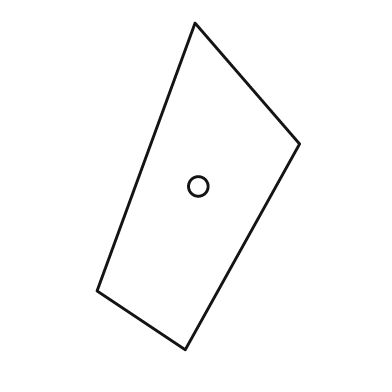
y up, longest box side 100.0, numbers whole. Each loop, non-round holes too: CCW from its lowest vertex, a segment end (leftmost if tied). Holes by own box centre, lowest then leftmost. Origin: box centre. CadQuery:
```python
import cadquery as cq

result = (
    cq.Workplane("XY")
    .moveTo(-4.0, -50.0)
    .lineTo(31.0, 13.0)
    .lineTo(-1.0, 50.0)
    .lineTo(-31.0, -32.0)
    .close()
    .moveTo(0.0, 0.0)
    .circle(3.0)
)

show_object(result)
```